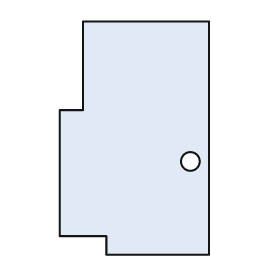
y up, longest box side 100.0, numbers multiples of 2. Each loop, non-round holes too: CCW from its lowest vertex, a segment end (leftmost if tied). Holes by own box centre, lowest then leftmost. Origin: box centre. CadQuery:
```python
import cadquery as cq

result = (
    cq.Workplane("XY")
    .moveTo(-12.0, -50.0)
    .lineTo(32.0, -50.0)
    .lineTo(32.0, 50.0)
    .lineTo(-22.0, 50.0)
    .lineTo(-22.0, 12.0)
    .lineTo(-32.0, 12.0)
    .lineTo(-32.0, -42.0)
    .lineTo(-12.0, -42.0)
    .close()
    .moveTo(24.0, -10.0)
    .circle(4.0)
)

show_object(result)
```